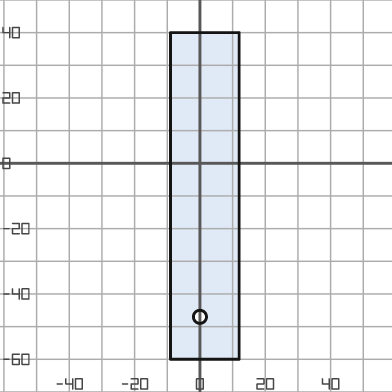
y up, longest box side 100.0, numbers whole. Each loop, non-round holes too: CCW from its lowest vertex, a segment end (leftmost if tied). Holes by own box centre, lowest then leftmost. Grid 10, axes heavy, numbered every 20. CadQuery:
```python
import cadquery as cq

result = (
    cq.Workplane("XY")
    .moveTo(-9.0, -60.0)
    .lineTo(12.0, -60.0)
    .lineTo(12.0, 40.0)
    .lineTo(-9.0, 40.0)
    .close()
    .moveTo(0.0, -47.0)
    .circle(2.0)
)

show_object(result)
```